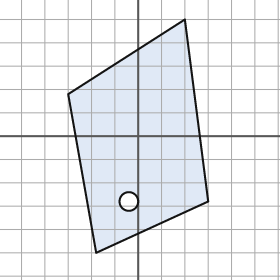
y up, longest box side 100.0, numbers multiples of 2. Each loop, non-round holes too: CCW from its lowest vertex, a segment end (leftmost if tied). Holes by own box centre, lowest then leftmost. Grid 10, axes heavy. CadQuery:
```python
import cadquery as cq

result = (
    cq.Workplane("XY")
    .moveTo(-18.0, -50.0)
    .lineTo(30.0, -28.0)
    .lineTo(20.0, 50.0)
    .lineTo(-30.0, 18.0)
    .close()
    .moveTo(-4.0, -28.0)
    .circle(4.0)
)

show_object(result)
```